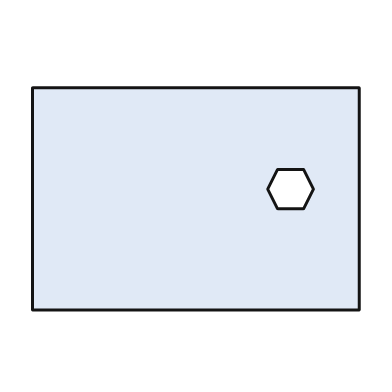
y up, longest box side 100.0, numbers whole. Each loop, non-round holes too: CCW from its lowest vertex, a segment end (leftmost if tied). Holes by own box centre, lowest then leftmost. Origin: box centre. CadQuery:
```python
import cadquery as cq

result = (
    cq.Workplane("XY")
    .moveTo(-50.0, -34.0)
    .lineTo(50.0, -34.0)
    .lineTo(50.0, 34.0)
    .lineTo(-50.0, 34.0)
    .close()
    .moveTo(25.0, -3.0)
    .lineTo(33.0, -3.0)
    .lineTo(36.0, 3.0)
    .lineTo(33.0, 9.0)
    .lineTo(25.0, 9.0)
    .lineTo(22.0, 3.0)
    .close()
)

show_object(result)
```